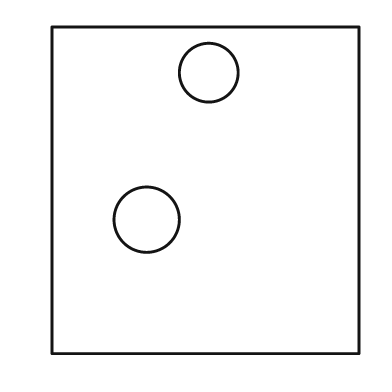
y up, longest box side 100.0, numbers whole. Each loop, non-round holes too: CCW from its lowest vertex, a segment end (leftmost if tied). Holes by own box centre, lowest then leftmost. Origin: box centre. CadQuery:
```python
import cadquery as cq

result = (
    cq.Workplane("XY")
    .moveTo(-47.0, -50.0)
    .lineTo(47.0, -50.0)
    .lineTo(47.0, 50.0)
    .lineTo(-47.0, 50.0)
    .close()
    .moveTo(-18.0, -9.0)
    .circle(10.0)
    .moveTo(1.0, 36.0)
    .circle(9.0)
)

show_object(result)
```